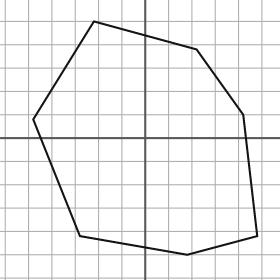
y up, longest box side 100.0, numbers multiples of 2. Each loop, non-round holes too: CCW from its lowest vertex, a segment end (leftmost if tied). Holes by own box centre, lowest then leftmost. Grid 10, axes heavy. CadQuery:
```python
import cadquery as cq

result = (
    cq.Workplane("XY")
    .moveTo(18.0, -50.0)
    .lineTo(48.0, -42.0)
    .lineTo(42.0, 10.0)
    .lineTo(22.0, 38.0)
    .lineTo(-22.0, 50.0)
    .lineTo(-48.0, 8.0)
    .lineTo(-28.0, -42.0)
    .close()
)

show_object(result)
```